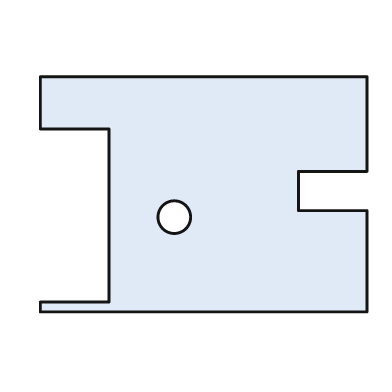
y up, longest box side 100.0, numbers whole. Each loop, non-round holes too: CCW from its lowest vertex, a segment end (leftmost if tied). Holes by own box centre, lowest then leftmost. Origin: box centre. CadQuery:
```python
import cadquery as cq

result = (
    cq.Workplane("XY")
    .moveTo(-50.0, -36.0)
    .lineTo(50.0, -36.0)
    .lineTo(50.0, -5.0)
    .lineTo(29.0, -5.0)
    .lineTo(29.0, 7.0)
    .lineTo(50.0, 7.0)
    .lineTo(50.0, 36.0)
    .lineTo(-50.0, 36.0)
    .lineTo(-50.0, 20.0)
    .lineTo(-29.0, 20.0)
    .lineTo(-29.0, -33.0)
    .lineTo(-50.0, -33.0)
    .close()
    .moveTo(-9.0, -7.0)
    .circle(5.0)
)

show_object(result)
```